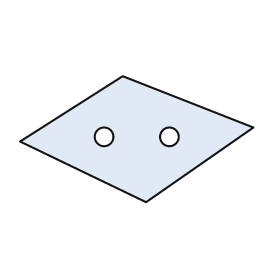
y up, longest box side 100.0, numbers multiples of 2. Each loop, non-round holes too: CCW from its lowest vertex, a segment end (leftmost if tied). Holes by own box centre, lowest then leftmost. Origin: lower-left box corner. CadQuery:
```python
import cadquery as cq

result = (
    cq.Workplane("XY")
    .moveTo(54.0, 0.0)
    .lineTo(100.0, 32.0)
    .lineTo(44.0, 54.0)
    .lineTo(0.0, 26.0)
    .close()
    .moveTo(36.0, 28.0)
    .circle(4.0)
    .moveTo(64.0, 28.0)
    .circle(4.0)
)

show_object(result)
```